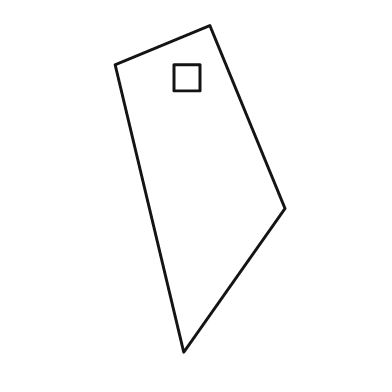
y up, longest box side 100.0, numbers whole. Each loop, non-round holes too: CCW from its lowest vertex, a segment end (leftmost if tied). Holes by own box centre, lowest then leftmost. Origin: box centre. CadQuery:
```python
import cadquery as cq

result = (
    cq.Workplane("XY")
    .moveTo(-5.0, -50.0)
    .lineTo(26.0, -6.0)
    .lineTo(3.0, 50.0)
    .lineTo(-26.0, 38.0)
    .close()
    .moveTo(-8.0, 30.0)
    .lineTo(0.0, 30.0)
    .lineTo(0.0, 38.0)
    .lineTo(-8.0, 38.0)
    .close()
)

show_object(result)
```